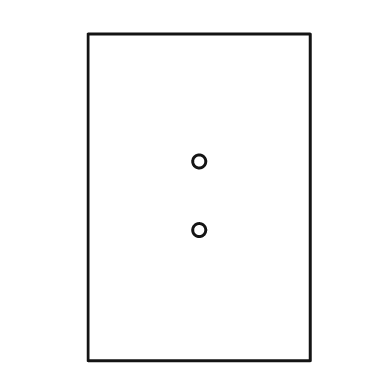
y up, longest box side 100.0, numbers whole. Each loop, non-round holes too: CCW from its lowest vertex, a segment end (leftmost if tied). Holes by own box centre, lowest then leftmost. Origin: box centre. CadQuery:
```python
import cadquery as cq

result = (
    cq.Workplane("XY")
    .moveTo(-34.0, -50.0)
    .lineTo(34.0, -50.0)
    .lineTo(34.0, 50.0)
    .lineTo(-34.0, 50.0)
    .close()
    .moveTo(0.0, -10.0)
    .circle(2.0)
    .moveTo(0.0, 11.0)
    .circle(2.0)
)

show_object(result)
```